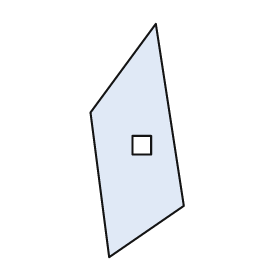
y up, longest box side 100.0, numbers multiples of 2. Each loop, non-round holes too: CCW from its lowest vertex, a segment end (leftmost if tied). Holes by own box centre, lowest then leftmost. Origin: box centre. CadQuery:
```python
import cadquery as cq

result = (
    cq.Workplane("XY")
    .moveTo(-12.0, -50.0)
    .lineTo(20.0, -28.0)
    .lineTo(8.0, 50.0)
    .lineTo(-20.0, 12.0)
    .close()
    .moveTo(-2.0, -6.0)
    .lineTo(6.0, -6.0)
    .lineTo(6.0, 2.0)
    .lineTo(-2.0, 2.0)
    .close()
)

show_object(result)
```